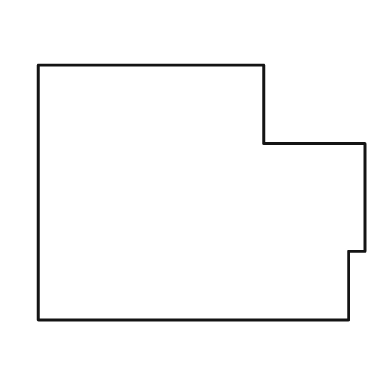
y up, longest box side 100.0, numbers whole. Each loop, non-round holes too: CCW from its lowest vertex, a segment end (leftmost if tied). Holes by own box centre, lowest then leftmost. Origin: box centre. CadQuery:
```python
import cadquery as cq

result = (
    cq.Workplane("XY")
    .moveTo(-50.0, -39.0)
    .lineTo(45.0, -39.0)
    .lineTo(45.0, -18.0)
    .lineTo(50.0, -18.0)
    .lineTo(50.0, 15.0)
    .lineTo(19.0, 15.0)
    .lineTo(19.0, 39.0)
    .lineTo(-50.0, 39.0)
    .close()
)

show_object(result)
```